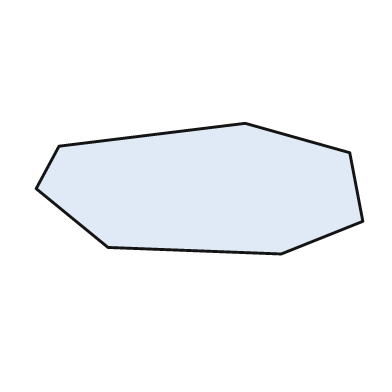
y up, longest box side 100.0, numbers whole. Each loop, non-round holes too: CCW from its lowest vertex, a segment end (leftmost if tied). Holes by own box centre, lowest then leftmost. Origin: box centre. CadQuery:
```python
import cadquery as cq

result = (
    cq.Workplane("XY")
    .moveTo(25.0, -20.0)
    .lineTo(50.0, -10.0)
    .lineTo(46.0, 11.0)
    .lineTo(14.0, 20.0)
    .lineTo(-43.0, 13.0)
    .lineTo(-50.0, 0.0)
    .lineTo(-28.0, -18.0)
    .close()
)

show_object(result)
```